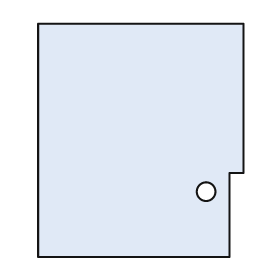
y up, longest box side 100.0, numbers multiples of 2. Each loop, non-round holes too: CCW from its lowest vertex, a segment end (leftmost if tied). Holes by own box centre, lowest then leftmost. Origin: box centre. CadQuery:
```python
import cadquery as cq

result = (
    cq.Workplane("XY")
    .moveTo(-44.0, -50.0)
    .lineTo(38.0, -50.0)
    .lineTo(38.0, -14.0)
    .lineTo(44.0, -14.0)
    .lineTo(44.0, 50.0)
    .lineTo(-44.0, 50.0)
    .close()
    .moveTo(28.0, -22.0)
    .circle(4.0)
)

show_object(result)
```